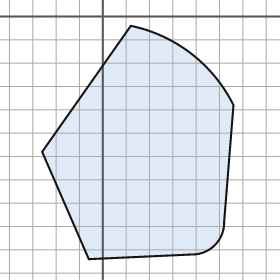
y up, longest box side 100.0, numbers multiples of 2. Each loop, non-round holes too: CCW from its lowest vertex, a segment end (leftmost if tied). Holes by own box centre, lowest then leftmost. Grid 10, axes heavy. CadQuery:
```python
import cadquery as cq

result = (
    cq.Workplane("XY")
    .moveTo(-6.0, -104.0)
    .lineTo(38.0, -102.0)
    .threePointArc((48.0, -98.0), (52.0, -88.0))
    .lineTo(56.0, -38.0)
    .threePointArc((38.0, -16.0), (12.0, -4.0))
    .lineTo(-26.0, -58.0)
    .close()
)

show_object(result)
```